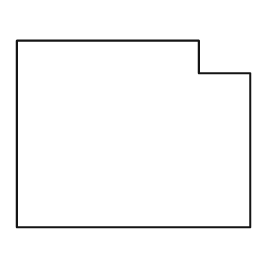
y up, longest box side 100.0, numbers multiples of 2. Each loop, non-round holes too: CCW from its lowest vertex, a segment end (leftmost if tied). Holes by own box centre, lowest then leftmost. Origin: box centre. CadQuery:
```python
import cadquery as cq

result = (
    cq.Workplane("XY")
    .moveTo(-50.0, -40.0)
    .lineTo(50.0, -40.0)
    .lineTo(50.0, 26.0)
    .lineTo(28.0, 26.0)
    .lineTo(28.0, 40.0)
    .lineTo(-50.0, 40.0)
    .close()
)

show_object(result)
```